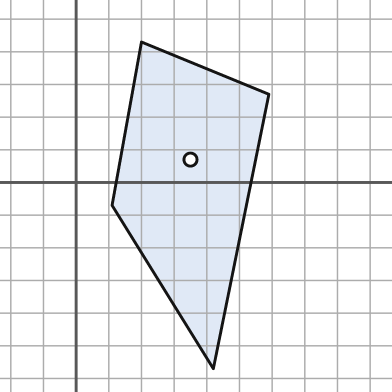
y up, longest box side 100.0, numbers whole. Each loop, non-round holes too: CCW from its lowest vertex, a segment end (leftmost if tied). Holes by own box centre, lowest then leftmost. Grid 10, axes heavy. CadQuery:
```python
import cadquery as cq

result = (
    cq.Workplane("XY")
    .moveTo(42.0, -57.0)
    .lineTo(59.0, 27.0)
    .lineTo(20.0, 43.0)
    .lineTo(11.0, -7.0)
    .close()
    .moveTo(35.0, 7.0)
    .circle(2.0)
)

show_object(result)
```